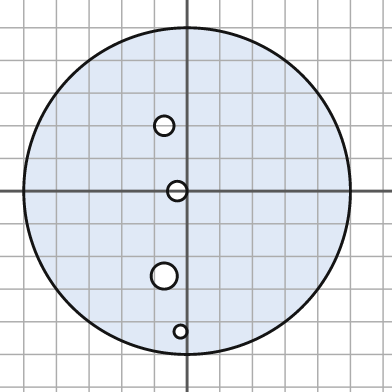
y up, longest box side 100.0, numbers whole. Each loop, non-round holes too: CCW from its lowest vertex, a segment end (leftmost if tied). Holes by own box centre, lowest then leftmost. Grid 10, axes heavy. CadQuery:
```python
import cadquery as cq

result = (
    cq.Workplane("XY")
    .moveTo(0.0, 0.0)
    .circle(50.0)
    .moveTo(-2.0, -43.0)
    .circle(2.0)
    .moveTo(-7.0, -26.0)
    .circle(4.0)
    .moveTo(-3.0, 0.0)
    .circle(3.0)
    .moveTo(-7.0, 20.0)
    .circle(3.0)
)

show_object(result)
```